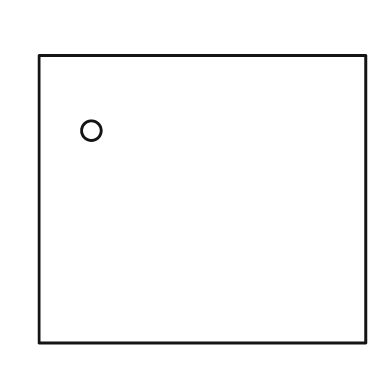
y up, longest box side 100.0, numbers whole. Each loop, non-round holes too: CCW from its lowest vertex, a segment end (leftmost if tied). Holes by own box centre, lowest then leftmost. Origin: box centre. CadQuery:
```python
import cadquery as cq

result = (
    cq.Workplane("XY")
    .moveTo(-50.0, -44.0)
    .lineTo(50.0, -44.0)
    .lineTo(50.0, 44.0)
    .lineTo(-50.0, 44.0)
    .close()
    .moveTo(-34.0, 21.0)
    .circle(3.0)
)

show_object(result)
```